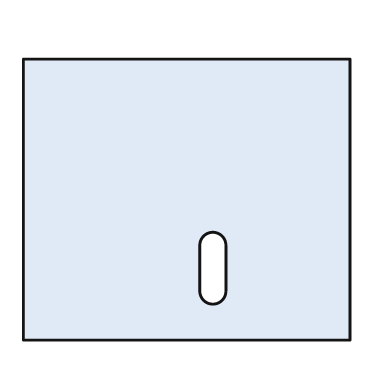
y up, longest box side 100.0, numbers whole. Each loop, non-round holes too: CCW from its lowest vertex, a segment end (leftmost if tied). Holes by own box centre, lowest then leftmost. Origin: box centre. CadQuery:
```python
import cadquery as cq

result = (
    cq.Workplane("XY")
    .moveTo(-50.0, -43.0)
    .lineTo(50.0, -43.0)
    .lineTo(50.0, 43.0)
    .lineTo(-50.0, 43.0)
    .close()
    .moveTo(4.0, -28.0)
    .threePointArc((8.0, -32.0), (12.0, -28.0))
    .lineTo(12.0, -14.0)
    .threePointArc((8.0, -10.0), (4.0, -14.0))
    .close()
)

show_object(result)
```